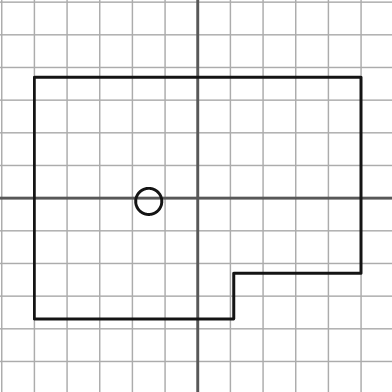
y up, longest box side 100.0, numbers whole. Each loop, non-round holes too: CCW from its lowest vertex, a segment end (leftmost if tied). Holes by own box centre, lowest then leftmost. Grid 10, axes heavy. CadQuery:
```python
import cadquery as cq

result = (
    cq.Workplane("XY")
    .moveTo(-50.0, -37.0)
    .lineTo(11.0, -37.0)
    .lineTo(11.0, -23.0)
    .lineTo(50.0, -23.0)
    .lineTo(50.0, 37.0)
    .lineTo(-50.0, 37.0)
    .close()
    .moveTo(-15.0, -1.0)
    .circle(4.0)
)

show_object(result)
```